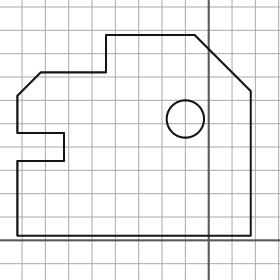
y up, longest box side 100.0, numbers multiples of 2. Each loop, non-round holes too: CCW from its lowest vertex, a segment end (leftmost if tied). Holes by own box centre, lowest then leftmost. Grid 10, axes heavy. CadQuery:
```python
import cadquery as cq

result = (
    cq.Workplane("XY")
    .moveTo(-82.0, 2.0)
    .lineTo(18.0, 2.0)
    .lineTo(18.0, 64.0)
    .lineTo(-6.0, 88.0)
    .lineTo(-44.0, 88.0)
    .lineTo(-44.0, 72.0)
    .lineTo(-72.0, 72.0)
    .lineTo(-82.0, 62.0)
    .lineTo(-82.0, 46.0)
    .lineTo(-62.0, 46.0)
    .lineTo(-62.0, 34.0)
    .lineTo(-82.0, 34.0)
    .close()
    .moveTo(-10.0, 52.0)
    .circle(8.0)
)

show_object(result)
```